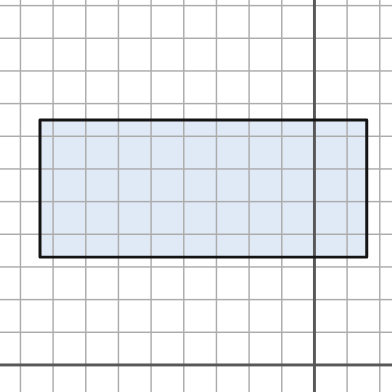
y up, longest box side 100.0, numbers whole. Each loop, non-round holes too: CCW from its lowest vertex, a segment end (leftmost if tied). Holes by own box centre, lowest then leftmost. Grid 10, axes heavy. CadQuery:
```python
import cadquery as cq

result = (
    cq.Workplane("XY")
    .moveTo(-84.0, 33.0)
    .lineTo(16.0, 33.0)
    .lineTo(16.0, 75.0)
    .lineTo(-84.0, 75.0)
    .close()
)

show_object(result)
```